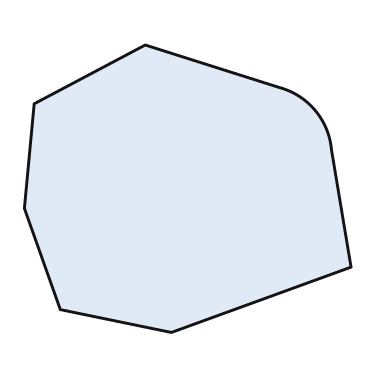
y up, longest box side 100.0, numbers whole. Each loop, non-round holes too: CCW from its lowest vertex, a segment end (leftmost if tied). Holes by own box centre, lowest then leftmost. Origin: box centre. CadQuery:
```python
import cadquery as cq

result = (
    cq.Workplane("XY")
    .moveTo(-5.0, -44.0)
    .lineTo(50.0, -24.0)
    .lineTo(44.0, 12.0)
    .threePointArc((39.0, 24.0), (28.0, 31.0))
    .lineTo(-13.0, 44.0)
    .lineTo(-47.0, 26.0)
    .lineTo(-50.0, -6.0)
    .lineTo(-39.0, -37.0)
    .close()
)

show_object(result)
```